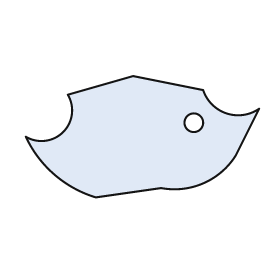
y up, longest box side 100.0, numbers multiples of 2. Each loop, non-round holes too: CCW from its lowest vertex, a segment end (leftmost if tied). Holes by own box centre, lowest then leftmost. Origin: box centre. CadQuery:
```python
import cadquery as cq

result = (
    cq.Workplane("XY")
    .moveTo(-20.0, -26.0)
    .lineTo(8.0, -22.0)
    .threePointArc((26.0, -20.0), (40.0, -8.0))
    .lineTo(50.0, 12.0)
    .threePointArc((36.0, 10.0), (26.0, 20.0))
    .lineTo(-4.0, 26.0)
    .lineTo(-32.0, 18.0)
    .threePointArc((-34.0, 2.0), (-50.0, 0.0))
    .threePointArc((-38.0, -16.0), (-20.0, -26.0))
    .close()
    .moveTo(22.0, 6.0)
    .circle(4.0)
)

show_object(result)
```